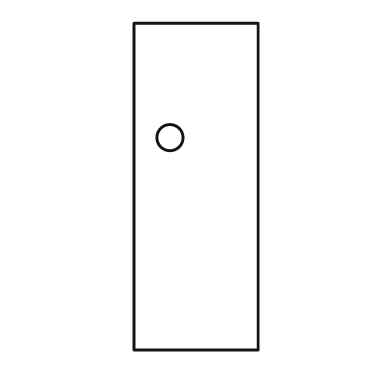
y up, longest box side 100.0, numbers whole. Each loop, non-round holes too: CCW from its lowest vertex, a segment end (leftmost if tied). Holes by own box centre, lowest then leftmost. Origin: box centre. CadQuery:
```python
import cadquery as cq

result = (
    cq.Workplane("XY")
    .moveTo(-19.0, -50.0)
    .lineTo(19.0, -50.0)
    .lineTo(19.0, 50.0)
    .lineTo(-19.0, 50.0)
    .close()
    .moveTo(-8.0, 15.0)
    .circle(4.0)
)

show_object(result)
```